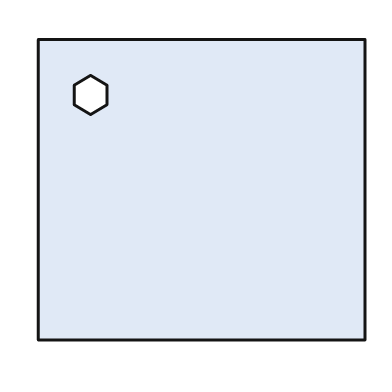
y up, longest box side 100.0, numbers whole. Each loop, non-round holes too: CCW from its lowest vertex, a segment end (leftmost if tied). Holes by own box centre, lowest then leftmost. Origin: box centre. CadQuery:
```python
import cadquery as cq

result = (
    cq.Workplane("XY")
    .moveTo(-50.0, -46.0)
    .lineTo(50.0, -46.0)
    .lineTo(50.0, 46.0)
    .lineTo(-50.0, 46.0)
    .close()
    .moveTo(-34.0, 23.0)
    .lineTo(-29.0, 26.0)
    .lineTo(-29.0, 32.0)
    .lineTo(-34.0, 35.0)
    .lineTo(-39.0, 32.0)
    .lineTo(-39.0, 26.0)
    .close()
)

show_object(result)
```